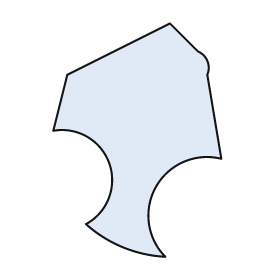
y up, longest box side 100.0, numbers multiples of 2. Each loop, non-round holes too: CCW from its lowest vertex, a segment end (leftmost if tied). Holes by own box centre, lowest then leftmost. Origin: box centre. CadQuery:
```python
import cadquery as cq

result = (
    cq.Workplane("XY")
    .moveTo(12.0, -50.0)
    .threePointArc((8.0, -20.0), (36.0, -8.0))
    .lineTo(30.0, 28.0)
    .threePointArc((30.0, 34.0), (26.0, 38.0))
    .lineTo(14.0, 50.0)
    .lineTo(-30.0, 28.0)
    .lineTo(-36.0, 4.0)
    .threePointArc((-12.0, -10.0), (-22.0, -36.0))
    .threePointArc((-6.0, -46.0), (12.0, -50.0))
    .close()
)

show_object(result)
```